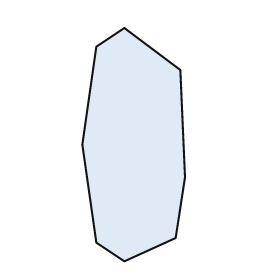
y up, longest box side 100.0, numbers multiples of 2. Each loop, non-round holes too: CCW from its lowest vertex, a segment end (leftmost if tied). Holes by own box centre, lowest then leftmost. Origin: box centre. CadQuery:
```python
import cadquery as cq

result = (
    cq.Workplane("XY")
    .moveTo(-4.0, -50.0)
    .lineTo(18.0, -40.0)
    .lineTo(22.0, -14.0)
    .lineTo(20.0, 32.0)
    .lineTo(-4.0, 50.0)
    .lineTo(-16.0, 42.0)
    .lineTo(-22.0, 0.0)
    .lineTo(-16.0, -42.0)
    .close()
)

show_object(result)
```